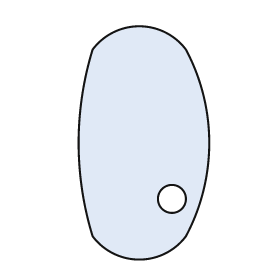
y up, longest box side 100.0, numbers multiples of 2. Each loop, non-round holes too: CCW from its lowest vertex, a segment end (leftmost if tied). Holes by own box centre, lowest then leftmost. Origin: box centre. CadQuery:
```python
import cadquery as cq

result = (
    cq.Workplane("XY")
    .moveTo(-22.0, -40.0)
    .threePointArc((-2.0, -50.0), (18.0, -40.0))
    .threePointArc((28.0, 0.0), (18.0, 40.0))
    .threePointArc((-2.0, 50.0), (-22.0, 40.0))
    .threePointArc((-28.0, 0.0), (-22.0, -40.0))
    .close()
    .moveTo(12.0, -24.0)
    .circle(6.0)
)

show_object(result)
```